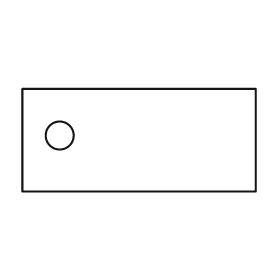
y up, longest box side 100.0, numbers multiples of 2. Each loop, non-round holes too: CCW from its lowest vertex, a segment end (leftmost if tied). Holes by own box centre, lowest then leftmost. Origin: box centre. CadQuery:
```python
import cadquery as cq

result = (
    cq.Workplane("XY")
    .moveTo(-50.0, -22.0)
    .lineTo(50.0, -22.0)
    .lineTo(50.0, 22.0)
    .lineTo(-50.0, 22.0)
    .close()
    .moveTo(-34.0, 2.0)
    .circle(6.0)
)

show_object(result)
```